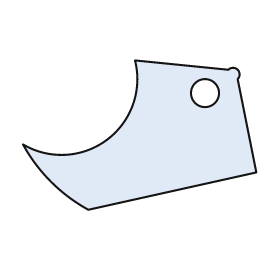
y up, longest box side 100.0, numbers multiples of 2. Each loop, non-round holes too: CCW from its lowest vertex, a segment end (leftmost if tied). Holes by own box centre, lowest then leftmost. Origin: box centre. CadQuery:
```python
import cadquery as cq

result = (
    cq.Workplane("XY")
    .moveTo(-22.0, -32.0)
    .lineTo(50.0, -16.0)
    .lineTo(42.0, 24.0)
    .threePointArc((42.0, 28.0), (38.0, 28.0))
    .lineTo(-2.0, 32.0)
    .threePointArc((-14.0, -2.0), (-50.0, -4.0))
    .threePointArc((-38.0, -20.0), (-22.0, -32.0))
    .close()
    .moveTo(28.0, 18.0)
    .circle(6.0)
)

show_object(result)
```